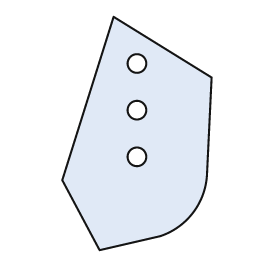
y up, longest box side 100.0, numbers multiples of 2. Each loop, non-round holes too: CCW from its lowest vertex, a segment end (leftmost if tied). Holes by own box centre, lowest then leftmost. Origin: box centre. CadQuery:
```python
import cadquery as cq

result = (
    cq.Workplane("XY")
    .moveTo(-16.0, -50.0)
    .lineTo(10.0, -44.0)
    .threePointArc((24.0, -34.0), (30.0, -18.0))
    .lineTo(32.0, 24.0)
    .lineTo(-10.0, 50.0)
    .lineTo(-32.0, -20.0)
    .close()
    .moveTo(0.0, -10.0)
    .circle(4.0)
    .moveTo(0.0, 10.0)
    .circle(4.0)
    .moveTo(0.0, 30.0)
    .circle(4.0)
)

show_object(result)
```